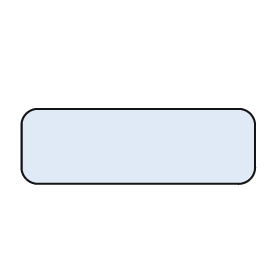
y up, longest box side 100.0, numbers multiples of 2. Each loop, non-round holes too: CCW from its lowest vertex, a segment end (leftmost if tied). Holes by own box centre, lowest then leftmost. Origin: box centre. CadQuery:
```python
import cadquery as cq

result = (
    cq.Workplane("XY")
    .moveTo(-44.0, -16.0)
    .lineTo(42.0, -16.0)
    .threePointArc((48.0, -14.0), (50.0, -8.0))
    .lineTo(50.0, 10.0)
    .threePointArc((48.0, 14.0), (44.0, 16.0))
    .lineTo(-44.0, 16.0)
    .threePointArc((-48.0, 14.0), (-50.0, 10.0))
    .lineTo(-50.0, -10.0)
    .threePointArc((-48.0, -14.0), (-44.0, -16.0))
    .close()
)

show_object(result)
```